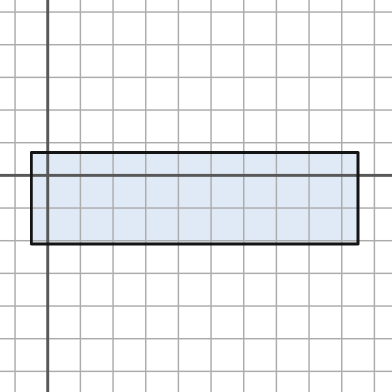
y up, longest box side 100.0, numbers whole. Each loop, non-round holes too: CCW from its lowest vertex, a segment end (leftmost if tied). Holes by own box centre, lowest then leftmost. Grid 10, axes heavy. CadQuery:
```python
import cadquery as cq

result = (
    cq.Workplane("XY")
    .moveTo(-5.0, -21.0)
    .lineTo(95.0, -21.0)
    .lineTo(95.0, 7.0)
    .lineTo(-5.0, 7.0)
    .close()
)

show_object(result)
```